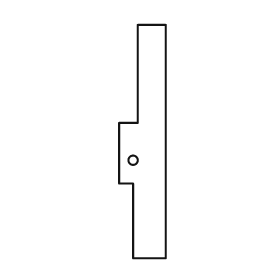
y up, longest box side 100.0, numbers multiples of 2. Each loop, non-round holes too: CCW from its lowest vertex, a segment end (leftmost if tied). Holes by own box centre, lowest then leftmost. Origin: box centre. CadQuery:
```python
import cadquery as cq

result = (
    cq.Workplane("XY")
    .moveTo(-4.0, -50.0)
    .lineTo(10.0, -50.0)
    .lineTo(10.0, 50.0)
    .lineTo(-2.0, 50.0)
    .lineTo(-2.0, 8.0)
    .lineTo(-10.0, 8.0)
    .lineTo(-10.0, -18.0)
    .lineTo(-4.0, -18.0)
    .close()
    .moveTo(-4.0, -8.0)
    .circle(2.0)
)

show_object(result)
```